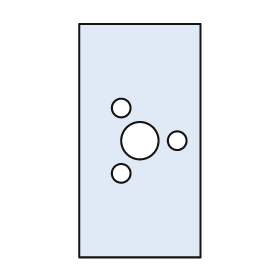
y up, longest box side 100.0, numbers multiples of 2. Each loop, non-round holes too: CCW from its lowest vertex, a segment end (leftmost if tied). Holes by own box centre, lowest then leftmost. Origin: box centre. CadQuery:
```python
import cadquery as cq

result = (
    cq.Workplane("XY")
    .moveTo(-26.0, -50.0)
    .lineTo(26.0, -50.0)
    .lineTo(26.0, 50.0)
    .lineTo(-26.0, 50.0)
    .close()
    .moveTo(-8.0, -14.0)
    .circle(4.0)
    .moveTo(0.0, 0.0)
    .circle(8.0)
    .moveTo(16.0, 0.0)
    .circle(4.0)
    .moveTo(-8.0, 14.0)
    .circle(4.0)
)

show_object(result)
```